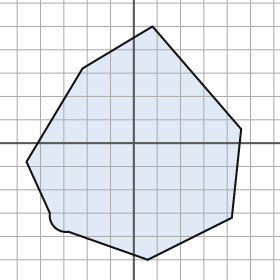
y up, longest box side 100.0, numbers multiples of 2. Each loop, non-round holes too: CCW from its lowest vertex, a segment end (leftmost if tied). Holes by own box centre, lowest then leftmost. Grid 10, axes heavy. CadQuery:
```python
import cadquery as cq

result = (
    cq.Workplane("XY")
    .moveTo(6.0, -50.0)
    .lineTo(42.0, -32.0)
    .lineTo(46.0, 6.0)
    .lineTo(8.0, 50.0)
    .lineTo(-22.0, 32.0)
    .lineTo(-46.0, -8.0)
    .lineTo(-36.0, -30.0)
    .threePointArc((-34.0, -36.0), (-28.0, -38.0))
    .close()
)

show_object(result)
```